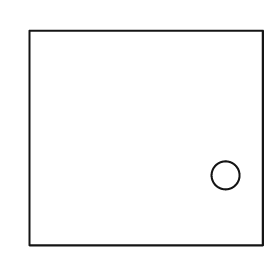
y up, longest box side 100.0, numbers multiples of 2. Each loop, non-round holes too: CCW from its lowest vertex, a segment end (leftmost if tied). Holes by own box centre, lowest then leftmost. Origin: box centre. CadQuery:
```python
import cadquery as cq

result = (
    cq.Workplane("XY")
    .moveTo(-50.0, -46.0)
    .lineTo(50.0, -46.0)
    .lineTo(50.0, 46.0)
    .lineTo(-50.0, 46.0)
    .close()
    .moveTo(34.0, -16.0)
    .circle(6.0)
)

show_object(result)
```